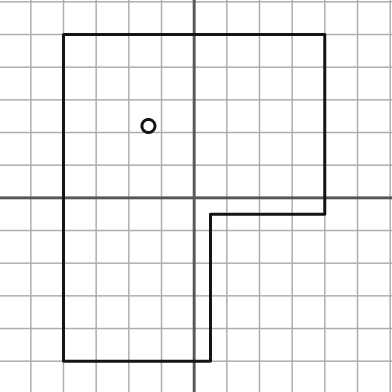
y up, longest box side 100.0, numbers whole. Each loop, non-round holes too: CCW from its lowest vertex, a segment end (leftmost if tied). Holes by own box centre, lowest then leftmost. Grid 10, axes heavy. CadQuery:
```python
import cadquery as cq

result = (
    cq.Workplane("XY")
    .moveTo(-40.0, -50.0)
    .lineTo(5.0, -50.0)
    .lineTo(5.0, -5.0)
    .lineTo(40.0, -5.0)
    .lineTo(40.0, 50.0)
    .lineTo(-40.0, 50.0)
    .close()
    .moveTo(-14.0, 22.0)
    .circle(2.0)
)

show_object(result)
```